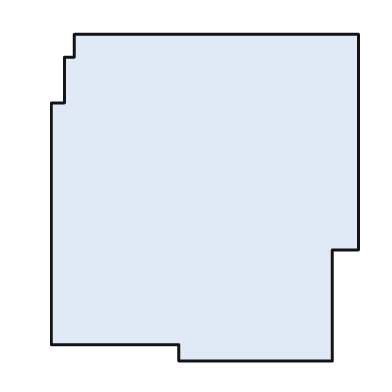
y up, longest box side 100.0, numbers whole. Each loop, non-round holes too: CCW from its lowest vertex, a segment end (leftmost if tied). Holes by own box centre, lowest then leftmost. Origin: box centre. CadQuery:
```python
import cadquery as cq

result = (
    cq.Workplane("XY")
    .moveTo(-8.0, -50.0)
    .lineTo(39.0, -50.0)
    .lineTo(39.0, -16.0)
    .lineTo(47.0, -16.0)
    .lineTo(47.0, 50.0)
    .lineTo(-40.0, 50.0)
    .lineTo(-40.0, 43.0)
    .lineTo(-43.0, 43.0)
    .lineTo(-43.0, 29.0)
    .lineTo(-47.0, 29.0)
    .lineTo(-47.0, -45.0)
    .lineTo(-8.0, -45.0)
    .close()
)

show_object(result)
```